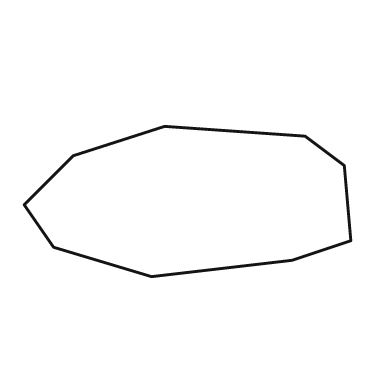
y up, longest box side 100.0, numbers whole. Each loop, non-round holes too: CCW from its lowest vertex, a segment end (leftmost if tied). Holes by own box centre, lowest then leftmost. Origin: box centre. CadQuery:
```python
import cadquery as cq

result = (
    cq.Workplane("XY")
    .moveTo(-11.0, -23.0)
    .lineTo(32.0, -18.0)
    .lineTo(50.0, -12.0)
    .lineTo(48.0, 11.0)
    .lineTo(36.0, 20.0)
    .lineTo(-7.0, 23.0)
    .lineTo(-35.0, 14.0)
    .lineTo(-50.0, -1.0)
    .lineTo(-41.0, -14.0)
    .close()
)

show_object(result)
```